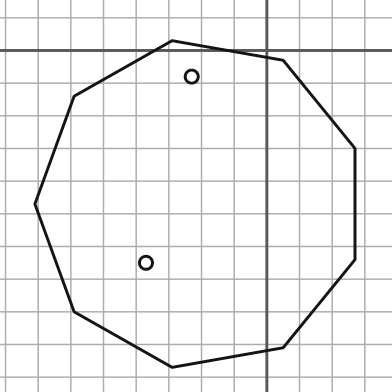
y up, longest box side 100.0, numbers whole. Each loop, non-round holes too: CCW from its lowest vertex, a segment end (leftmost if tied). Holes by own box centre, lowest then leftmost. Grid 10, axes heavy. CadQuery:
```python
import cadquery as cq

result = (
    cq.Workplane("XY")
    .moveTo(-29.0, -97.0)
    .lineTo(5.0, -91.0)
    .lineTo(27.0, -64.0)
    .lineTo(27.0, -30.0)
    .lineTo(5.0, -3.0)
    .lineTo(-29.0, 3.0)
    .lineTo(-59.0, -14.0)
    .lineTo(-71.0, -47.0)
    .lineTo(-59.0, -80.0)
    .close()
    .moveTo(-37.0, -65.0)
    .circle(2.0)
    .moveTo(-23.0, -8.0)
    .circle(2.0)
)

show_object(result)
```